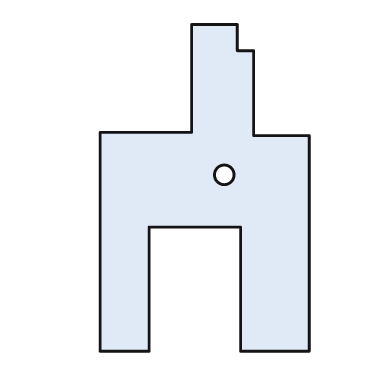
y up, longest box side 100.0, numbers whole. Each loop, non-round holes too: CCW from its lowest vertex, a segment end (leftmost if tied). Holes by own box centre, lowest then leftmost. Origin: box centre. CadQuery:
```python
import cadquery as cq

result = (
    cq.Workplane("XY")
    .moveTo(-32.0, -50.0)
    .lineTo(-17.0, -50.0)
    .lineTo(-17.0, -12.0)
    .lineTo(11.0, -12.0)
    .lineTo(11.0, -50.0)
    .lineTo(32.0, -50.0)
    .lineTo(32.0, 16.0)
    .lineTo(15.0, 16.0)
    .lineTo(15.0, 42.0)
    .lineTo(10.0, 42.0)
    .lineTo(10.0, 50.0)
    .lineTo(-4.0, 50.0)
    .lineTo(-4.0, 17.0)
    .lineTo(-32.0, 17.0)
    .close()
    .moveTo(6.0, 4.0)
    .circle(3.0)
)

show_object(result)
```